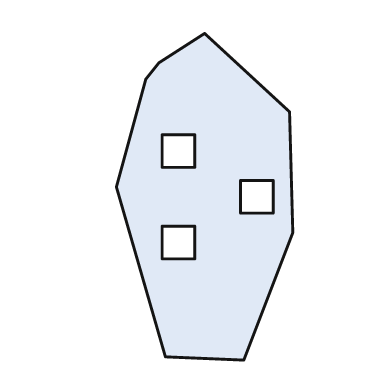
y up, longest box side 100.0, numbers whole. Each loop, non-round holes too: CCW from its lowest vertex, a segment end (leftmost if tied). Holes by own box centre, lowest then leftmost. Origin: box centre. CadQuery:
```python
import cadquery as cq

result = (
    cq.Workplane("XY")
    .moveTo(12.0, -50.0)
    .lineTo(27.0, -11.0)
    .lineTo(26.0, 26.0)
    .lineTo(0.0, 50.0)
    .lineTo(-14.0, 41.0)
    .lineTo(-18.0, 36.0)
    .lineTo(-27.0, 3.0)
    .lineTo(-12.0, -49.0)
    .close()
    .moveTo(-13.0, -19.0)
    .lineTo(-3.0, -19.0)
    .lineTo(-3.0, -9.0)
    .lineTo(-13.0, -9.0)
    .close()
    .moveTo(11.0, -5.0)
    .lineTo(21.0, -5.0)
    .lineTo(21.0, 5.0)
    .lineTo(11.0, 5.0)
    .close()
    .moveTo(-13.0, 9.0)
    .lineTo(-3.0, 9.0)
    .lineTo(-3.0, 19.0)
    .lineTo(-13.0, 19.0)
    .close()
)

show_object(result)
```